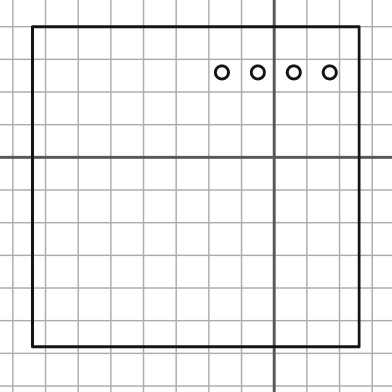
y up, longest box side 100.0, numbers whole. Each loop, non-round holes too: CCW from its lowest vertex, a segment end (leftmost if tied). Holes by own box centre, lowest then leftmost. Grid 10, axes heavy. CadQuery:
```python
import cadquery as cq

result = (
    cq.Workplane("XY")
    .moveTo(-74.0, -58.0)
    .lineTo(26.0, -58.0)
    .lineTo(26.0, 40.0)
    .lineTo(-74.0, 40.0)
    .close()
    .moveTo(-16.0, 26.0)
    .circle(2.0)
    .moveTo(-5.0, 26.0)
    .circle(2.0)
    .moveTo(6.0, 26.0)
    .circle(2.0)
    .moveTo(17.0, 26.0)
    .circle(2.0)
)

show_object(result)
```